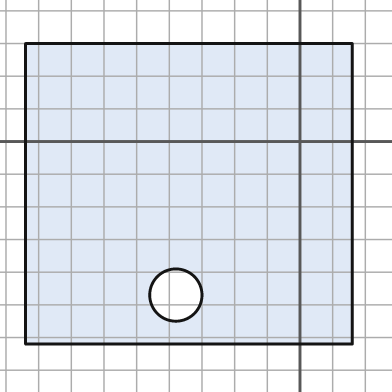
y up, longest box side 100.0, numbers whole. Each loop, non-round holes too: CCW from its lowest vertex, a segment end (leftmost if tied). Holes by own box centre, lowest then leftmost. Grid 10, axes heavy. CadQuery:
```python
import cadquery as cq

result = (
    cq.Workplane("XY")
    .moveTo(-84.0, -62.0)
    .lineTo(16.0, -62.0)
    .lineTo(16.0, 30.0)
    .lineTo(-84.0, 30.0)
    .close()
    .moveTo(-38.0, -47.0)
    .circle(8.0)
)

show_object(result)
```